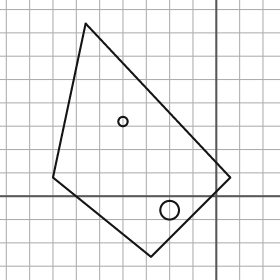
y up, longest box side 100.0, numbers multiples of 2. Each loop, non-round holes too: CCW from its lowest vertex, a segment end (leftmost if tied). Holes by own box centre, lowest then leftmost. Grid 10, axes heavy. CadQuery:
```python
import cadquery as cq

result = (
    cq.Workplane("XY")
    .moveTo(-28.0, -26.0)
    .lineTo(6.0, 8.0)
    .lineTo(-56.0, 74.0)
    .lineTo(-70.0, 8.0)
    .close()
    .moveTo(-20.0, -6.0)
    .circle(4.0)
    .moveTo(-40.0, 32.0)
    .circle(2.0)
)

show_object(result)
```